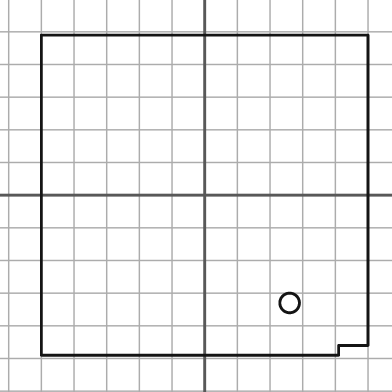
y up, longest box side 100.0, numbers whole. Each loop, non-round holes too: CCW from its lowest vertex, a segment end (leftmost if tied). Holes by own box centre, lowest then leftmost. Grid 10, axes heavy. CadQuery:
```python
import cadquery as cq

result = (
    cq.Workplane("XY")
    .moveTo(-50.0, -49.0)
    .lineTo(41.0, -49.0)
    .lineTo(41.0, -46.0)
    .lineTo(50.0, -46.0)
    .lineTo(50.0, 49.0)
    .lineTo(-50.0, 49.0)
    .close()
    .moveTo(26.0, -33.0)
    .circle(3.0)
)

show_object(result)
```